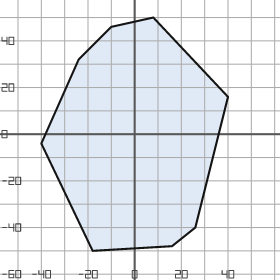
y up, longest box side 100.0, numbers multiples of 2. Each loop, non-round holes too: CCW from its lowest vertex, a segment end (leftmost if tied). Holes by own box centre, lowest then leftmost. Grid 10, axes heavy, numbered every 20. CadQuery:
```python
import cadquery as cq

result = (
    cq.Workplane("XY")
    .moveTo(-18.0, -50.0)
    .lineTo(16.0, -48.0)
    .lineTo(26.0, -40.0)
    .lineTo(40.0, 16.0)
    .lineTo(8.0, 50.0)
    .lineTo(-10.0, 46.0)
    .lineTo(-24.0, 32.0)
    .lineTo(-40.0, -4.0)
    .close()
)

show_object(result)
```